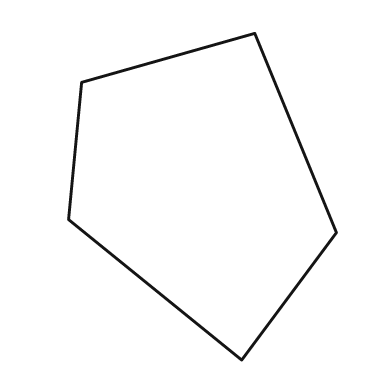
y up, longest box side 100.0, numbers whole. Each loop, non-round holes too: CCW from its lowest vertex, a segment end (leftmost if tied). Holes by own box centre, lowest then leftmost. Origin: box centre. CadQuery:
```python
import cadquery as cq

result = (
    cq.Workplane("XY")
    .moveTo(12.0, -50.0)
    .lineTo(41.0, -11.0)
    .lineTo(16.0, 50.0)
    .lineTo(-37.0, 35.0)
    .lineTo(-41.0, -7.0)
    .close()
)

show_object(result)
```